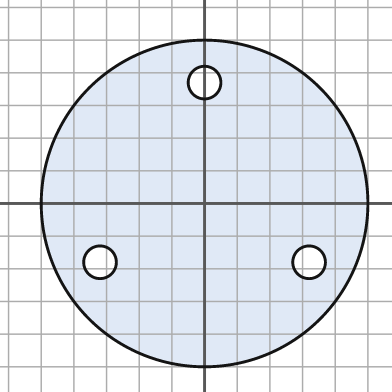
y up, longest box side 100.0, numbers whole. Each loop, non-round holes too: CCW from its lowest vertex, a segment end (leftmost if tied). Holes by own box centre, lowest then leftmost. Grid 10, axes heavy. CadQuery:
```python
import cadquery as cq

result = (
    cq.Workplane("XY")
    .moveTo(0.0, 0.0)
    .circle(50.0)
    .moveTo(-32.0, -18.0)
    .circle(5.0)
    .moveTo(32.0, -18.0)
    .circle(5.0)
    .moveTo(0.0, 37.0)
    .circle(5.0)
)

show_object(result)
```